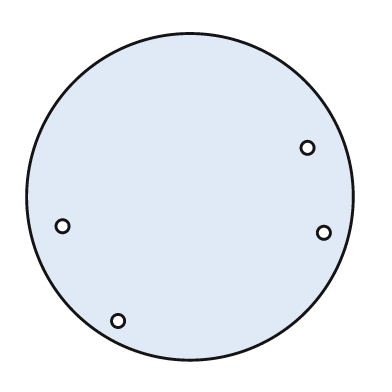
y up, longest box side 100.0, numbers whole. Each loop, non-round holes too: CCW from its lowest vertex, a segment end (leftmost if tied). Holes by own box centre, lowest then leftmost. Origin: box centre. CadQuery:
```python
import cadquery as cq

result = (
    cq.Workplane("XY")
    .moveTo(0.0, 0.0)
    .circle(50.0)
    .moveTo(-22.0, -38.0)
    .circle(2.0)
    .moveTo(41.0, -11.0)
    .circle(2.0)
    .moveTo(-39.0, -9.0)
    .circle(2.0)
    .moveTo(36.0, 15.0)
    .circle(2.0)
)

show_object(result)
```